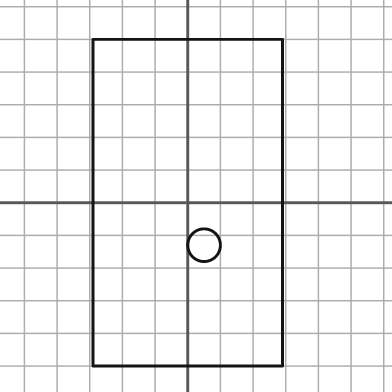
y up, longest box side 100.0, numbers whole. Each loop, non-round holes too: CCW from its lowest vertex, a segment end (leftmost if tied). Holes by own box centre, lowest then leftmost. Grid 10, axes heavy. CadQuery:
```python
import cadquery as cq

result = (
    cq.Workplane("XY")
    .moveTo(-29.0, -50.0)
    .lineTo(29.0, -50.0)
    .lineTo(29.0, 50.0)
    .lineTo(-29.0, 50.0)
    .close()
    .moveTo(5.0, -13.0)
    .circle(5.0)
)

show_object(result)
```